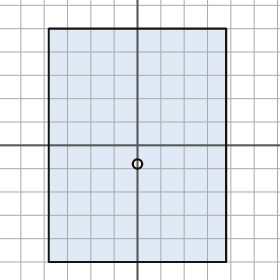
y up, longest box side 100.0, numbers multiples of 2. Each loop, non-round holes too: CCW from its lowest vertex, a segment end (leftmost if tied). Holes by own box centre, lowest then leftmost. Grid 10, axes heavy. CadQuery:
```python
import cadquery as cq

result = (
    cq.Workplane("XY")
    .moveTo(-38.0, -50.0)
    .lineTo(38.0, -50.0)
    .lineTo(38.0, 50.0)
    .lineTo(-38.0, 50.0)
    .close()
    .moveTo(0.0, -8.0)
    .circle(2.0)
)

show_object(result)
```